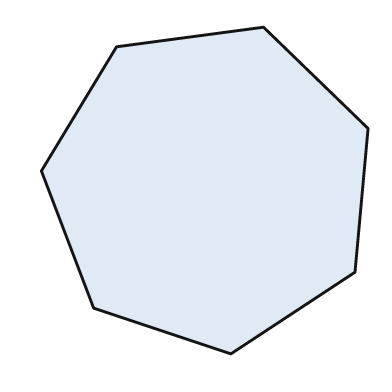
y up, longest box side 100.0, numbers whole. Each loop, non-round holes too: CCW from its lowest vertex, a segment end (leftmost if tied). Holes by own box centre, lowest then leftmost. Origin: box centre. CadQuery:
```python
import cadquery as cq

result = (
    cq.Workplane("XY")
    .moveTo(8.0, -50.0)
    .lineTo(46.0, -25.0)
    .lineTo(50.0, 19.0)
    .lineTo(18.0, 50.0)
    .lineTo(-27.0, 44.0)
    .lineTo(-50.0, 6.0)
    .lineTo(-34.0, -36.0)
    .close()
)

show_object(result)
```